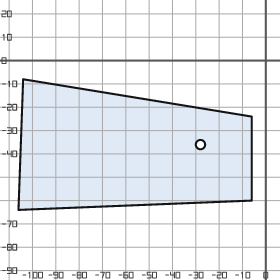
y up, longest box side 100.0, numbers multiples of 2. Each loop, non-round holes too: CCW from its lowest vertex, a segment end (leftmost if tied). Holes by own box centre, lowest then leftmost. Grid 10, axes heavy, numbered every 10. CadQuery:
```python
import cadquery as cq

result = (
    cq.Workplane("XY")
    .moveTo(-106.0, -64.0)
    .lineTo(-6.0, -60.0)
    .lineTo(-6.0, -24.0)
    .lineTo(-104.0, -8.0)
    .close()
    .moveTo(-28.0, -36.0)
    .circle(2.0)
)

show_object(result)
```